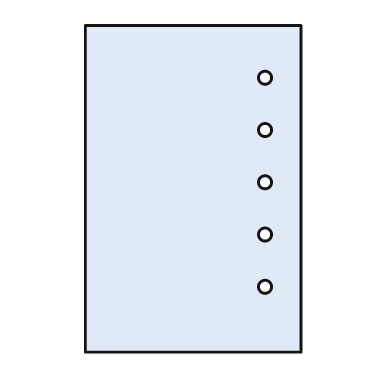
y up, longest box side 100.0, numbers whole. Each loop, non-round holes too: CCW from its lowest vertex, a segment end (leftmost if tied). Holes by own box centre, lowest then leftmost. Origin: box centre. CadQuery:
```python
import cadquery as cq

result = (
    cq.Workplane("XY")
    .moveTo(-33.0, -50.0)
    .lineTo(33.0, -50.0)
    .lineTo(33.0, 50.0)
    .lineTo(-33.0, 50.0)
    .close()
    .moveTo(22.0, -30.0)
    .circle(2.0)
    .moveTo(22.0, -14.0)
    .circle(2.0)
    .moveTo(22.0, 2.0)
    .circle(2.0)
    .moveTo(22.0, 18.0)
    .circle(2.0)
    .moveTo(22.0, 34.0)
    .circle(2.0)
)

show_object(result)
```